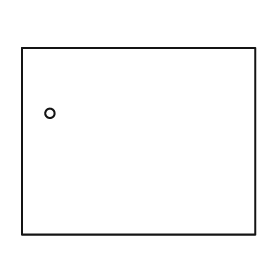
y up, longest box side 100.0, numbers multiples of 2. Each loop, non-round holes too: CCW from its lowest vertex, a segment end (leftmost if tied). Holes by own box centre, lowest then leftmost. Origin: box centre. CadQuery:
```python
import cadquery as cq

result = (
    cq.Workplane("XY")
    .moveTo(-50.0, -40.0)
    .lineTo(50.0, -40.0)
    .lineTo(50.0, 40.0)
    .lineTo(-50.0, 40.0)
    .close()
    .moveTo(-38.0, 12.0)
    .circle(2.0)
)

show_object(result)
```